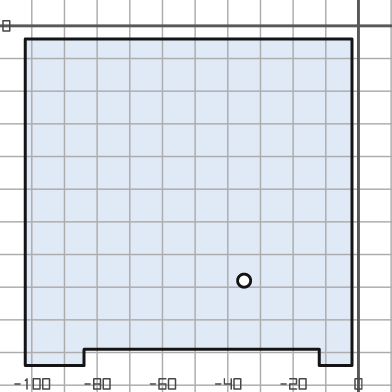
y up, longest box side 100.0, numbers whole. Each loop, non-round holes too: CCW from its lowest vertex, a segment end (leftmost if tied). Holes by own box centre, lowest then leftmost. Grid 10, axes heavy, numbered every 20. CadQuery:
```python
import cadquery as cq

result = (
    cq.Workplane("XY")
    .moveTo(-102.0, -104.0)
    .lineTo(-84.0, -104.0)
    .lineTo(-84.0, -99.0)
    .lineTo(-12.0, -99.0)
    .lineTo(-12.0, -104.0)
    .lineTo(-2.0, -104.0)
    .lineTo(-2.0, -4.0)
    .lineTo(-102.0, -4.0)
    .close()
    .moveTo(-35.0, -78.0)
    .circle(2.0)
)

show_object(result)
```